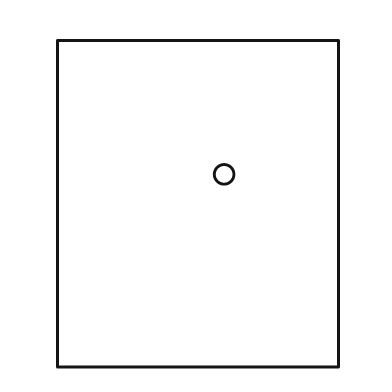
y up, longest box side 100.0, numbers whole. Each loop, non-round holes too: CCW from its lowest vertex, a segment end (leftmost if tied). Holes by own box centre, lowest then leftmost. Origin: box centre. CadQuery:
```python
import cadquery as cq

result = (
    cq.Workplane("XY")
    .moveTo(-43.0, -50.0)
    .lineTo(43.0, -50.0)
    .lineTo(43.0, 50.0)
    .lineTo(-43.0, 50.0)
    .close()
    .moveTo(8.0, 9.0)
    .circle(3.0)
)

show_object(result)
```